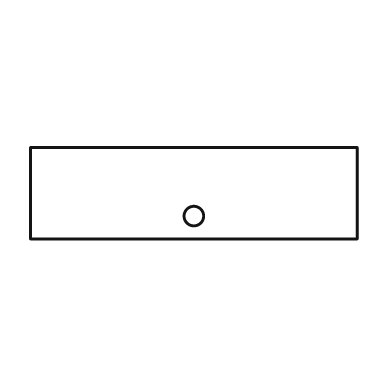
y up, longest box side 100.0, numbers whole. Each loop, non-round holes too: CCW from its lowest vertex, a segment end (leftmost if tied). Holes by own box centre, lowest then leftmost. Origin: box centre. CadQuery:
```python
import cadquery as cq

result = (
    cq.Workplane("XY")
    .moveTo(-50.0, -14.0)
    .lineTo(50.0, -14.0)
    .lineTo(50.0, 14.0)
    .lineTo(-50.0, 14.0)
    .close()
    .moveTo(0.0, -7.0)
    .circle(3.0)
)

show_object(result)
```